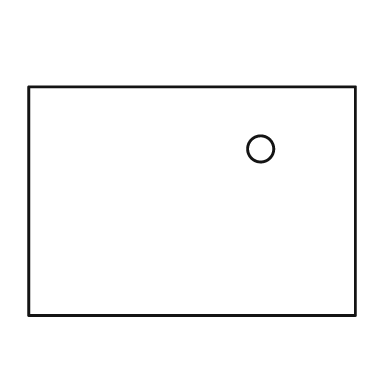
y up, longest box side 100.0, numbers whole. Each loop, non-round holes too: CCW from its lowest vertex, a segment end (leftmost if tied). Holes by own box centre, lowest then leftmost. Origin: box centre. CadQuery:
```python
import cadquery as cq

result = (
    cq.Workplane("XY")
    .moveTo(-50.0, -35.0)
    .lineTo(50.0, -35.0)
    .lineTo(50.0, 35.0)
    .lineTo(-50.0, 35.0)
    .close()
    .moveTo(21.0, 16.0)
    .circle(4.0)
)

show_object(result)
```